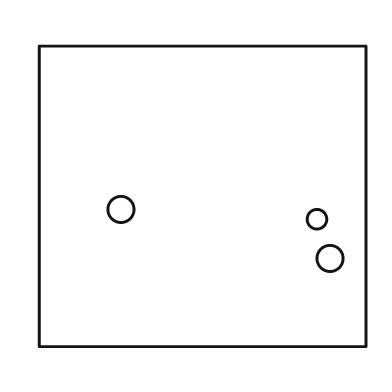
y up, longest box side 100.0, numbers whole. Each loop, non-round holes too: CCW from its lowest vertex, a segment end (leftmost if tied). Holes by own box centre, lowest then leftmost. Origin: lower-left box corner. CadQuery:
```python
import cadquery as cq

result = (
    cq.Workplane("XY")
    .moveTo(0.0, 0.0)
    .lineTo(100.0, 0.0)
    .lineTo(100.0, 92.0)
    .lineTo(0.0, 92.0)
    .close()
    .moveTo(89.0, 27.0)
    .circle(4.0)
    .moveTo(85.0, 39.0)
    .circle(3.0)
    .moveTo(25.0, 42.0)
    .circle(4.0)
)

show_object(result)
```